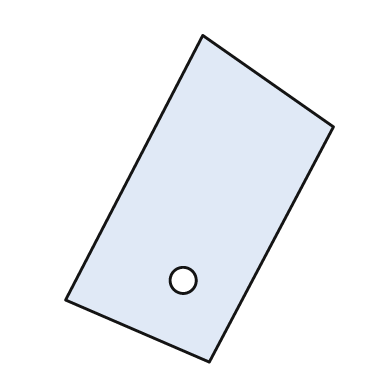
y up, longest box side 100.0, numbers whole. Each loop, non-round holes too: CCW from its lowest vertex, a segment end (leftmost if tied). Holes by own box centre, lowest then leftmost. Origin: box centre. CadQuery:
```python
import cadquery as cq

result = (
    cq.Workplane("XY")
    .moveTo(3.0, -50.0)
    .lineTo(41.0, 22.0)
    .lineTo(1.0, 50.0)
    .lineTo(-41.0, -31.0)
    .close()
    .moveTo(-5.0, -25.0)
    .circle(4.0)
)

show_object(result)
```